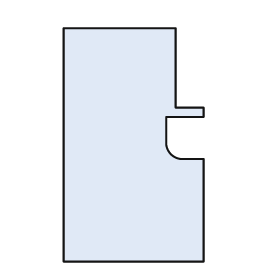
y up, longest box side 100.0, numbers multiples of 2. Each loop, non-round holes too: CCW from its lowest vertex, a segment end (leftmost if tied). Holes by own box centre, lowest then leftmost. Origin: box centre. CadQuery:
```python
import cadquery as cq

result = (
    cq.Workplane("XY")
    .moveTo(-30.0, -50.0)
    .lineTo(30.0, -50.0)
    .lineTo(30.0, -6.0)
    .lineTo(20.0, -6.0)
    .threePointArc((16.0, -4.0), (14.0, 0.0))
    .lineTo(14.0, 12.0)
    .lineTo(30.0, 12.0)
    .lineTo(30.0, 16.0)
    .lineTo(18.0, 16.0)
    .lineTo(18.0, 50.0)
    .lineTo(-30.0, 50.0)
    .close()
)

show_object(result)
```